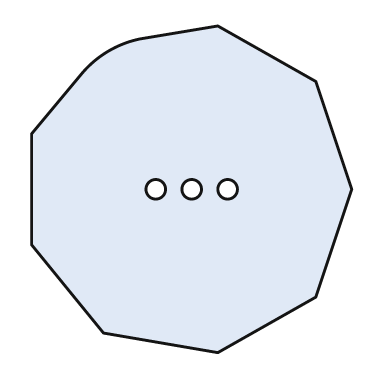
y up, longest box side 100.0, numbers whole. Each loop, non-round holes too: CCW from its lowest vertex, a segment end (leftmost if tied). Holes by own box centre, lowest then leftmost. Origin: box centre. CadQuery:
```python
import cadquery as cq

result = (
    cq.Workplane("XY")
    .moveTo(8.0, -50.0)
    .lineTo(38.0, -33.0)
    .lineTo(49.0, 0.0)
    .lineTo(38.0, 33.0)
    .lineTo(8.0, 50.0)
    .lineTo(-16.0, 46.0)
    .threePointArc((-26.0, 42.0), (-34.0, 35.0))
    .lineTo(-49.0, 17.0)
    .lineTo(-49.0, -17.0)
    .lineTo(-27.0, -44.0)
    .close()
    .moveTo(-11.0, 0.0)
    .circle(3.0)
    .moveTo(0.0, 0.0)
    .circle(3.0)
    .moveTo(11.0, 0.0)
    .circle(3.0)
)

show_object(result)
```